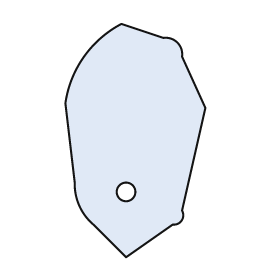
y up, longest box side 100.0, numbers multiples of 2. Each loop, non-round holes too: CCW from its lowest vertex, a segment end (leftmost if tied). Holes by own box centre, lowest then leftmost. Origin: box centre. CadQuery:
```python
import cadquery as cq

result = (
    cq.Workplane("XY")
    .moveTo(-4.0, -50.0)
    .lineTo(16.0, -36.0)
    .threePointArc((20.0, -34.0), (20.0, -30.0))
    .lineTo(30.0, 14.0)
    .lineTo(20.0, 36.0)
    .threePointArc((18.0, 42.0), (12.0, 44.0))
    .lineTo(-6.0, 50.0)
    .threePointArc((-22.0, 36.0), (-30.0, 16.0))
    .lineTo(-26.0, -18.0)
    .threePointArc((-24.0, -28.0), (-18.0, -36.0))
    .close()
    .moveTo(-4.0, -22.0)
    .circle(4.0)
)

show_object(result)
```